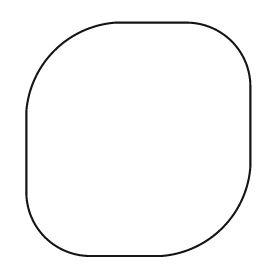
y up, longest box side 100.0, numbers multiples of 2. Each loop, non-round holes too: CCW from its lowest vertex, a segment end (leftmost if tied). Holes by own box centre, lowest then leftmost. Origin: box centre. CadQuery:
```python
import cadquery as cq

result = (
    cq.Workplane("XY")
    .moveTo(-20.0, -50.0)
    .lineTo(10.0, -50.0)
    .threePointArc((36.0, -38.0), (48.0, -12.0))
    .lineTo(48.0, 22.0)
    .threePointArc((40.0, 42.0), (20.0, 50.0))
    .lineTo(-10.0, 50.0)
    .threePointArc((-36.0, 38.0), (-48.0, 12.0))
    .lineTo(-48.0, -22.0)
    .threePointArc((-40.0, -42.0), (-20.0, -50.0))
    .close()
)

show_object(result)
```